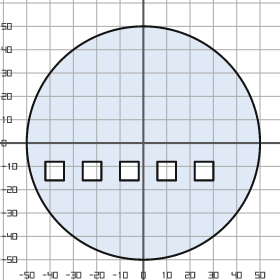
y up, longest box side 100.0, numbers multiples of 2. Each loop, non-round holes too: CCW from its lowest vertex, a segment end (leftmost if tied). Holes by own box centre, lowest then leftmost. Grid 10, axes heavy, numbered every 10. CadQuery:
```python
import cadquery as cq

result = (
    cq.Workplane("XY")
    .moveTo(0.0, 0.0)
    .circle(50.0)
    .moveTo(-42.0, -16.0)
    .lineTo(-34.0, -16.0)
    .lineTo(-34.0, -8.0)
    .lineTo(-42.0, -8.0)
    .close()
    .moveTo(-26.0, -16.0)
    .lineTo(-18.0, -16.0)
    .lineTo(-18.0, -8.0)
    .lineTo(-26.0, -8.0)
    .close()
    .moveTo(-10.0, -16.0)
    .lineTo(-2.0, -16.0)
    .lineTo(-2.0, -8.0)
    .lineTo(-10.0, -8.0)
    .close()
    .moveTo(6.0, -16.0)
    .lineTo(14.0, -16.0)
    .lineTo(14.0, -8.0)
    .lineTo(6.0, -8.0)
    .close()
    .moveTo(22.0, -16.0)
    .lineTo(30.0, -16.0)
    .lineTo(30.0, -8.0)
    .lineTo(22.0, -8.0)
    .close()
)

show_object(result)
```